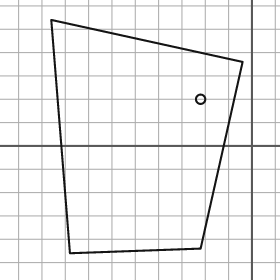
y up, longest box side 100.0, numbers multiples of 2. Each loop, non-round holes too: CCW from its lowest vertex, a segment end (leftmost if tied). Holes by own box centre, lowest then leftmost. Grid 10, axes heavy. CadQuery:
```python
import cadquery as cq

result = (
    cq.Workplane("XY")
    .moveTo(-78.0, -46.0)
    .lineTo(-22.0, -44.0)
    .lineTo(-4.0, 36.0)
    .lineTo(-86.0, 54.0)
    .close()
    .moveTo(-22.0, 20.0)
    .circle(2.0)
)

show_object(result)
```